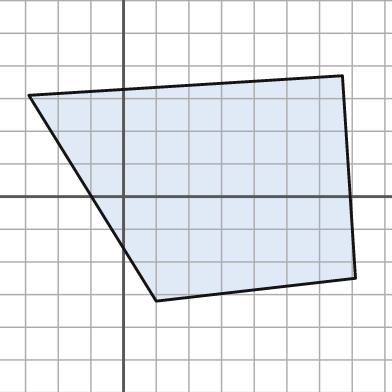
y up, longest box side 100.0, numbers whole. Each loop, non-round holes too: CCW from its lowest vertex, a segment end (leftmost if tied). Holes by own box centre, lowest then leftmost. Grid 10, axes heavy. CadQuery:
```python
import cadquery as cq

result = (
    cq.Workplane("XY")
    .moveTo(10.0, -32.0)
    .lineTo(71.0, -25.0)
    .lineTo(67.0, 37.0)
    .lineTo(-29.0, 31.0)
    .close()
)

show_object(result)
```